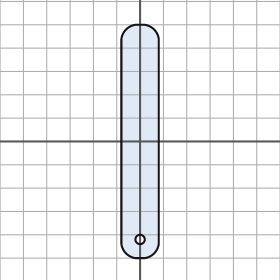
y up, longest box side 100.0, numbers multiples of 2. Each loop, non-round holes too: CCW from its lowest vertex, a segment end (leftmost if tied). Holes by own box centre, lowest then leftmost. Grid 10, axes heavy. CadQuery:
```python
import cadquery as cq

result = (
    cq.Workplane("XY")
    .moveTo(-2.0, -50.0)
    .lineTo(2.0, -50.0)
    .threePointArc((6.0, -48.0), (8.0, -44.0))
    .lineTo(8.0, 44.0)
    .threePointArc((6.0, 48.0), (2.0, 50.0))
    .lineTo(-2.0, 50.0)
    .threePointArc((-6.0, 48.0), (-8.0, 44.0))
    .lineTo(-8.0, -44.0)
    .threePointArc((-6.0, -48.0), (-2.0, -50.0))
    .close()
    .moveTo(0.0, -42.0)
    .circle(2.0)
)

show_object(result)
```